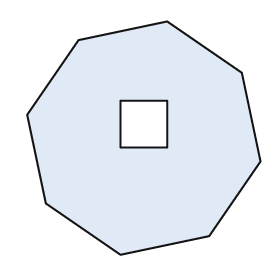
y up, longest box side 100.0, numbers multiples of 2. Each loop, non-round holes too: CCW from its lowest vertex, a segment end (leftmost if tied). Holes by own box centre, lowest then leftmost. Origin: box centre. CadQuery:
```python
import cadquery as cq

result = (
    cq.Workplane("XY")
    .moveTo(-10.0, -50.0)
    .lineTo(28.0, -42.0)
    .lineTo(50.0, -10.0)
    .lineTo(42.0, 28.0)
    .lineTo(10.0, 50.0)
    .lineTo(-28.0, 42.0)
    .lineTo(-50.0, 10.0)
    .lineTo(-42.0, -28.0)
    .close()
    .moveTo(-10.0, -4.0)
    .lineTo(10.0, -4.0)
    .lineTo(10.0, 16.0)
    .lineTo(-10.0, 16.0)
    .close()
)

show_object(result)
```